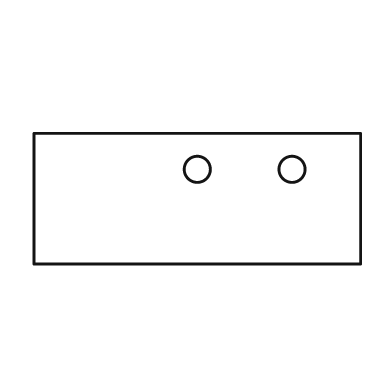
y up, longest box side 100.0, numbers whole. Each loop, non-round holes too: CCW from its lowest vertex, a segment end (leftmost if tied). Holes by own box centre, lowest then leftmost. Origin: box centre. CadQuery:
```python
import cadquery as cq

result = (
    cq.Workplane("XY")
    .moveTo(-50.0, -20.0)
    .lineTo(50.0, -20.0)
    .lineTo(50.0, 20.0)
    .lineTo(-50.0, 20.0)
    .close()
    .moveTo(0.0, 9.0)
    .circle(4.0)
    .moveTo(29.0, 9.0)
    .circle(4.0)
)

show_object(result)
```